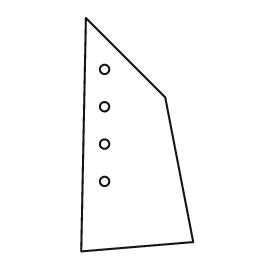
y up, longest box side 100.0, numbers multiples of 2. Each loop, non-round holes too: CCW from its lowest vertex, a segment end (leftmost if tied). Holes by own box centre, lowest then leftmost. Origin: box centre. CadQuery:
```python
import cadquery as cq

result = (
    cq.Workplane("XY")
    .moveTo(-24.0, -50.0)
    .lineTo(24.0, -46.0)
    .lineTo(12.0, 16.0)
    .lineTo(-22.0, 50.0)
    .close()
    .moveTo(-14.0, -20.0)
    .circle(2.0)
    .moveTo(-14.0, -4.0)
    .circle(2.0)
    .moveTo(-14.0, 12.0)
    .circle(2.0)
    .moveTo(-14.0, 28.0)
    .circle(2.0)
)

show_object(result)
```